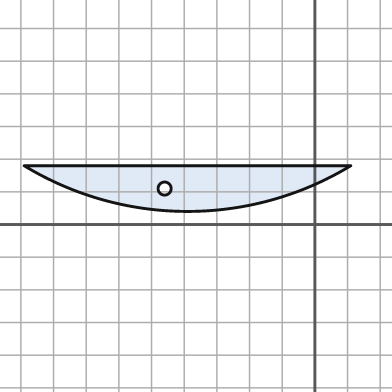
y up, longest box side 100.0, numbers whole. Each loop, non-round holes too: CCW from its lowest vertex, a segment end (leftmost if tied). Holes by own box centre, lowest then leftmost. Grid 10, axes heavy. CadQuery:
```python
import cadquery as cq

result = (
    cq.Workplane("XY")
    .moveTo(-89.0, 18.0)
    .threePointArc((-39.0, 4.0), (11.0, 18.0))
    .close()
    .moveTo(-46.0, 11.0)
    .circle(2.0)
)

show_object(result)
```